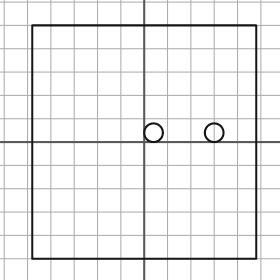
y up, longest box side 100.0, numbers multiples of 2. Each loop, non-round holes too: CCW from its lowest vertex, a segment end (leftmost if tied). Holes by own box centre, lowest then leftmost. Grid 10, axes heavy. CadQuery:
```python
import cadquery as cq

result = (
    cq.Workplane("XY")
    .moveTo(-48.0, -50.0)
    .lineTo(48.0, -50.0)
    .lineTo(48.0, 50.0)
    .lineTo(-48.0, 50.0)
    .close()
    .moveTo(4.0, 4.0)
    .circle(4.0)
    .moveTo(30.0, 4.0)
    .circle(4.0)
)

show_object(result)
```